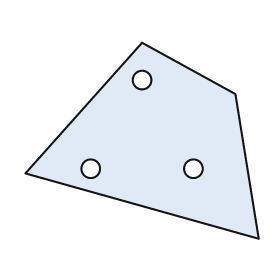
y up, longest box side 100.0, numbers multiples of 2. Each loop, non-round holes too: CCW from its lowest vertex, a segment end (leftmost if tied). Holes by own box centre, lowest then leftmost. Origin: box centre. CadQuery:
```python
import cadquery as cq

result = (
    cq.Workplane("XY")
    .moveTo(50.0, -42.0)
    .lineTo(40.0, 20.0)
    .lineTo(0.0, 42.0)
    .lineTo(-50.0, -14.0)
    .close()
    .moveTo(-22.0, -12.0)
    .circle(4.0)
    .moveTo(22.0, -12.0)
    .circle(4.0)
    .moveTo(0.0, 26.0)
    .circle(4.0)
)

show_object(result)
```